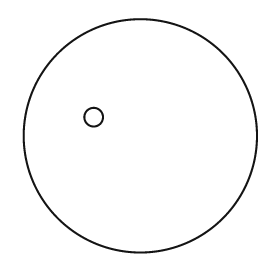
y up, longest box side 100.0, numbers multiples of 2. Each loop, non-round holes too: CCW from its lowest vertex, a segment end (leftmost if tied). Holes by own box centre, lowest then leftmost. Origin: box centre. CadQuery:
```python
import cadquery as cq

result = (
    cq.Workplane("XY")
    .moveTo(0.0, 0.0)
    .circle(50.0)
    .moveTo(-20.0, 8.0)
    .circle(4.0)
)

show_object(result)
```